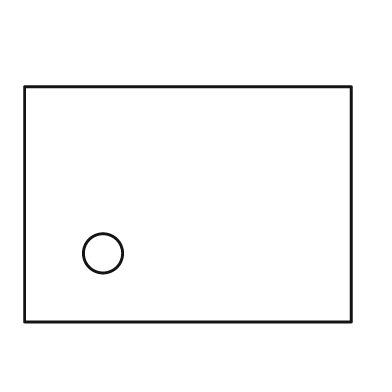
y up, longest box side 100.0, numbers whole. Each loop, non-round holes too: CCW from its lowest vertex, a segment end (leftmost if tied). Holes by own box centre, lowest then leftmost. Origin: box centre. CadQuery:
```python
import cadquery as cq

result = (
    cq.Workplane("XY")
    .moveTo(-50.0, -36.0)
    .lineTo(50.0, -36.0)
    .lineTo(50.0, 36.0)
    .lineTo(-50.0, 36.0)
    .close()
    .moveTo(-26.0, -15.0)
    .circle(6.0)
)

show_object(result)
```